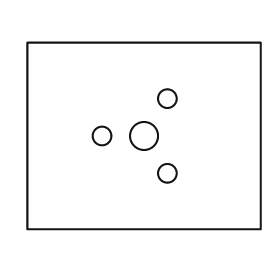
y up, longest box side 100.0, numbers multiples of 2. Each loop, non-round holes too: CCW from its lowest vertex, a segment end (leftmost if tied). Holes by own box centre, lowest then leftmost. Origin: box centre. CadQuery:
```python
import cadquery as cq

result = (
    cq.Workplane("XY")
    .moveTo(-50.0, -40.0)
    .lineTo(50.0, -40.0)
    .lineTo(50.0, 40.0)
    .lineTo(-50.0, 40.0)
    .close()
    .moveTo(10.0, -16.0)
    .circle(4.0)
    .moveTo(-18.0, 0.0)
    .circle(4.0)
    .moveTo(0.0, 0.0)
    .circle(6.0)
    .moveTo(10.0, 16.0)
    .circle(4.0)
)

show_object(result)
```